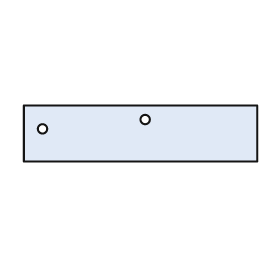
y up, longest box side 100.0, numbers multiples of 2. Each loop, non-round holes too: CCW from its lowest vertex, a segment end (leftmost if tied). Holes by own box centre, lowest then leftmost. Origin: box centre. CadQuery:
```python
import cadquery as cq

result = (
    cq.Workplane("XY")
    .moveTo(-50.0, -12.0)
    .lineTo(50.0, -12.0)
    .lineTo(50.0, 12.0)
    .lineTo(-50.0, 12.0)
    .close()
    .moveTo(-42.0, 2.0)
    .circle(2.0)
    .moveTo(2.0, 6.0)
    .circle(2.0)
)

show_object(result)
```